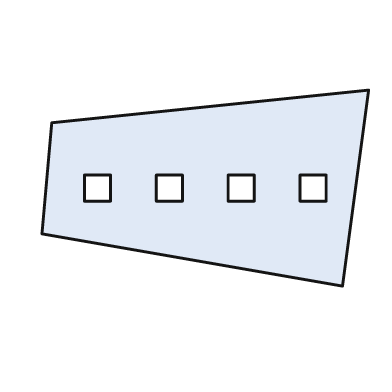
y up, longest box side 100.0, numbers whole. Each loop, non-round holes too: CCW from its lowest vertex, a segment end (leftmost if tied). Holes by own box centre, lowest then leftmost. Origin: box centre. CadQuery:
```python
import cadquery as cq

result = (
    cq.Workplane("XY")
    .moveTo(42.0, -30.0)
    .lineTo(50.0, 30.0)
    .lineTo(-47.0, 20.0)
    .lineTo(-50.0, -14.0)
    .close()
    .moveTo(-37.0, -4.0)
    .lineTo(-29.0, -4.0)
    .lineTo(-29.0, 4.0)
    .lineTo(-37.0, 4.0)
    .close()
    .moveTo(-15.0, -4.0)
    .lineTo(-7.0, -4.0)
    .lineTo(-7.0, 4.0)
    .lineTo(-15.0, 4.0)
    .close()
    .moveTo(7.0, -4.0)
    .lineTo(15.0, -4.0)
    .lineTo(15.0, 4.0)
    .lineTo(7.0, 4.0)
    .close()
    .moveTo(29.0, -4.0)
    .lineTo(37.0, -4.0)
    .lineTo(37.0, 4.0)
    .lineTo(29.0, 4.0)
    .close()
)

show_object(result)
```